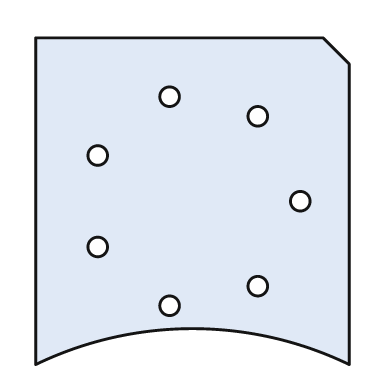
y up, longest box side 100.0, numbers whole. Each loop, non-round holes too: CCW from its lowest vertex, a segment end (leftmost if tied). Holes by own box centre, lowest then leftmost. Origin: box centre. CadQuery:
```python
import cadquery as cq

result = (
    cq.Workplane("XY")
    .moveTo(-48.0, -50.0)
    .threePointArc((0.0, -39.0), (48.0, -50.0))
    .lineTo(48.0, 42.0)
    .lineTo(40.0, 50.0)
    .lineTo(-48.0, 50.0)
    .close()
    .moveTo(-7.0, -32.0)
    .circle(3.0)
    .moveTo(20.0, -26.0)
    .circle(3.0)
    .moveTo(-29.0, -14.0)
    .circle(3.0)
    .moveTo(33.0, 0.0)
    .circle(3.0)
    .moveTo(-29.0, 14.0)
    .circle(3.0)
    .moveTo(20.0, 26.0)
    .circle(3.0)
    .moveTo(-7.0, 32.0)
    .circle(3.0)
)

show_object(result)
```